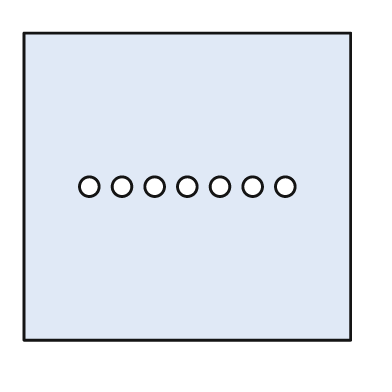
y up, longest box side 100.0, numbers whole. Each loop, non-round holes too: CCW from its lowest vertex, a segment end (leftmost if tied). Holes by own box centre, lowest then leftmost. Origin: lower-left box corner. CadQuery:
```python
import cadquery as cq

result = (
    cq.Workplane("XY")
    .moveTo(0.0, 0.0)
    .lineTo(100.0, 0.0)
    .lineTo(100.0, 94.0)
    .lineTo(0.0, 94.0)
    .close()
    .moveTo(20.0, 47.0)
    .circle(3.0)
    .moveTo(30.0, 47.0)
    .circle(3.0)
    .moveTo(40.0, 47.0)
    .circle(3.0)
    .moveTo(50.0, 47.0)
    .circle(3.0)
    .moveTo(60.0, 47.0)
    .circle(3.0)
    .moveTo(70.0, 47.0)
    .circle(3.0)
    .moveTo(80.0, 47.0)
    .circle(3.0)
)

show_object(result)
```